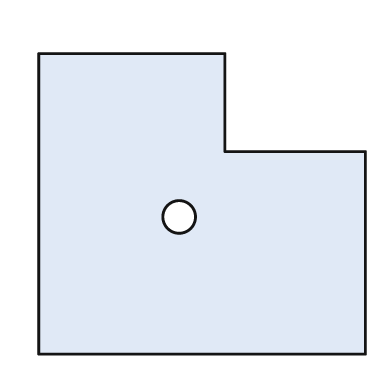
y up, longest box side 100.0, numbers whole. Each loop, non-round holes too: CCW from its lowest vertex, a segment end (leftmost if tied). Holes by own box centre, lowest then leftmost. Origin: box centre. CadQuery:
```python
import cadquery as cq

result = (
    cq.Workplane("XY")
    .moveTo(-50.0, -46.0)
    .lineTo(50.0, -46.0)
    .lineTo(50.0, 16.0)
    .lineTo(7.0, 16.0)
    .lineTo(7.0, 46.0)
    .lineTo(-50.0, 46.0)
    .close()
    .moveTo(-7.0, -4.0)
    .circle(5.0)
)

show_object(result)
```